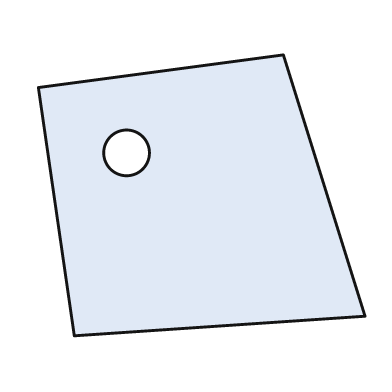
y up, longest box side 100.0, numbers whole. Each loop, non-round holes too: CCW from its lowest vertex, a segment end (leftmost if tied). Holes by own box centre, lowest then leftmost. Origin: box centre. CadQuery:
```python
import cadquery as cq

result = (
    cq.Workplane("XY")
    .moveTo(-39.0, -43.0)
    .lineTo(50.0, -37.0)
    .lineTo(25.0, 43.0)
    .lineTo(-50.0, 33.0)
    .close()
    .moveTo(-23.0, 13.0)
    .circle(7.0)
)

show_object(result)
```